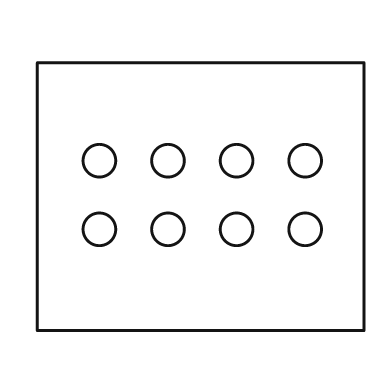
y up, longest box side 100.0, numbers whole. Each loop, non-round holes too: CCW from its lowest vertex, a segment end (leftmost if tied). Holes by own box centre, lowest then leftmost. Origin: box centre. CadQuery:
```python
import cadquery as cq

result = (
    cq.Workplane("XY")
    .moveTo(-50.0, -41.0)
    .lineTo(50.0, -41.0)
    .lineTo(50.0, 41.0)
    .lineTo(-50.0, 41.0)
    .close()
    .moveTo(-31.0, -10.0)
    .circle(5.0)
    .moveTo(-10.0, -10.0)
    .circle(5.0)
    .moveTo(11.0, -10.0)
    .circle(5.0)
    .moveTo(32.0, -10.0)
    .circle(5.0)
    .moveTo(-31.0, 11.0)
    .circle(5.0)
    .moveTo(-10.0, 11.0)
    .circle(5.0)
    .moveTo(11.0, 11.0)
    .circle(5.0)
    .moveTo(32.0, 11.0)
    .circle(5.0)
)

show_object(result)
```